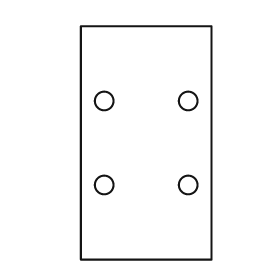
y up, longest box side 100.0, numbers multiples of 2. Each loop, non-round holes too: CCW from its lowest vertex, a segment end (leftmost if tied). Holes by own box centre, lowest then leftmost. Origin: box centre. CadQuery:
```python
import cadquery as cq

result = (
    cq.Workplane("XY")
    .moveTo(-28.0, -50.0)
    .lineTo(28.0, -50.0)
    .lineTo(28.0, 50.0)
    .lineTo(-28.0, 50.0)
    .close()
    .moveTo(-18.0, -18.0)
    .circle(4.0)
    .moveTo(18.0, -18.0)
    .circle(4.0)
    .moveTo(-18.0, 18.0)
    .circle(4.0)
    .moveTo(18.0, 18.0)
    .circle(4.0)
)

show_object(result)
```